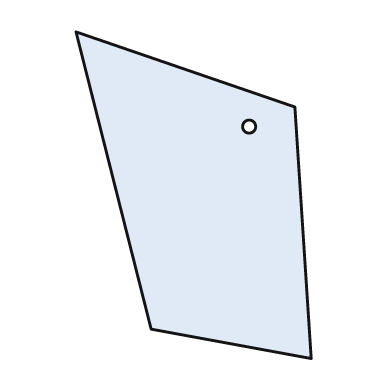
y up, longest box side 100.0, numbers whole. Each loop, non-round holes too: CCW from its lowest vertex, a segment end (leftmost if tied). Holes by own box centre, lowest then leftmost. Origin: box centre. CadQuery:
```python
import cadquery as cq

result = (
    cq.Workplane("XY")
    .moveTo(36.0, -50.0)
    .lineTo(31.0, 27.0)
    .lineTo(-36.0, 50.0)
    .lineTo(-13.0, -41.0)
    .close()
    .moveTo(17.0, 21.0)
    .circle(2.0)
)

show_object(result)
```